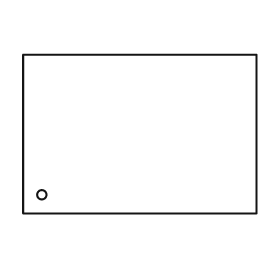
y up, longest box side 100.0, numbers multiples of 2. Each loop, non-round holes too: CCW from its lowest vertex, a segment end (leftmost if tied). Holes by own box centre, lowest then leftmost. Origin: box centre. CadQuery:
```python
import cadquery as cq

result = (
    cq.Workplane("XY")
    .moveTo(-50.0, -34.0)
    .lineTo(50.0, -34.0)
    .lineTo(50.0, 34.0)
    .lineTo(-50.0, 34.0)
    .close()
    .moveTo(-42.0, -26.0)
    .circle(2.0)
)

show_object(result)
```